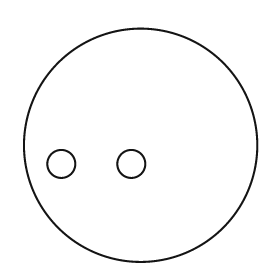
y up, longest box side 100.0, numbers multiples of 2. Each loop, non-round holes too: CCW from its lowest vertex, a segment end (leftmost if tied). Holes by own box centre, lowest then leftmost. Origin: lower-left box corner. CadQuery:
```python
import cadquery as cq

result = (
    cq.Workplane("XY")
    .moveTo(50.0, 50.0)
    .circle(50.0)
    .moveTo(16.0, 42.0)
    .circle(6.0)
    .moveTo(46.0, 42.0)
    .circle(6.0)
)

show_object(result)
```